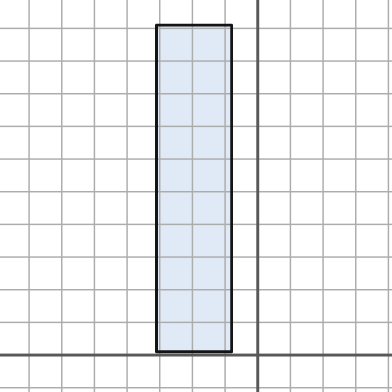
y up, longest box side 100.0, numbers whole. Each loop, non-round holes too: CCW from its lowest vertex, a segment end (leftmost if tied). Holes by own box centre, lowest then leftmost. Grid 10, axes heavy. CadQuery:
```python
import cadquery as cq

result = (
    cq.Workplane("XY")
    .moveTo(-31.0, 1.0)
    .lineTo(-8.0, 1.0)
    .lineTo(-8.0, 101.0)
    .lineTo(-31.0, 101.0)
    .close()
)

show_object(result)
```